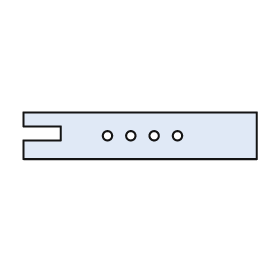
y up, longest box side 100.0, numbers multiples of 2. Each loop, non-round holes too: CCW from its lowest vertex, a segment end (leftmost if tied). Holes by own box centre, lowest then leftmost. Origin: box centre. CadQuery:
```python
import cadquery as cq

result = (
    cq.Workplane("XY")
    .moveTo(-50.0, -10.0)
    .lineTo(50.0, -10.0)
    .lineTo(50.0, 10.0)
    .lineTo(-50.0, 10.0)
    .lineTo(-50.0, 4.0)
    .lineTo(-34.0, 4.0)
    .lineTo(-34.0, -2.0)
    .lineTo(-50.0, -2.0)
    .close()
    .moveTo(-14.0, 0.0)
    .circle(2.0)
    .moveTo(-4.0, 0.0)
    .circle(2.0)
    .moveTo(6.0, 0.0)
    .circle(2.0)
    .moveTo(16.0, 0.0)
    .circle(2.0)
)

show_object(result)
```